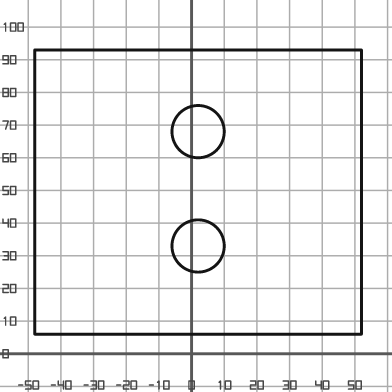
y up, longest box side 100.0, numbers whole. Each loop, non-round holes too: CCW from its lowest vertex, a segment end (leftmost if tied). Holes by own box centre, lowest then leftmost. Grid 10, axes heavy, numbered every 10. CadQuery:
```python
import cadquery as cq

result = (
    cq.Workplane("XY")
    .moveTo(-48.0, 6.0)
    .lineTo(52.0, 6.0)
    .lineTo(52.0, 93.0)
    .lineTo(-48.0, 93.0)
    .close()
    .moveTo(2.0, 33.0)
    .circle(8.0)
    .moveTo(2.0, 68.0)
    .circle(8.0)
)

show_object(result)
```